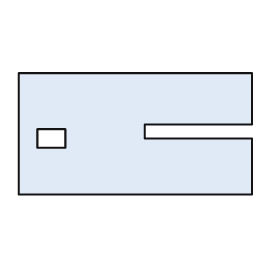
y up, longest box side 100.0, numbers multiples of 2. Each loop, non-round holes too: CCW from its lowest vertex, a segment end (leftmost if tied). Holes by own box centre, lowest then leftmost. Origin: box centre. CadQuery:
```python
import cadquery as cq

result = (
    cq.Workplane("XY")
    .moveTo(-50.0, -26.0)
    .lineTo(50.0, -26.0)
    .lineTo(50.0, -2.0)
    .lineTo(4.0, -2.0)
    .lineTo(4.0, 4.0)
    .lineTo(50.0, 4.0)
    .lineTo(50.0, 26.0)
    .lineTo(-50.0, 26.0)
    .close()
    .moveTo(-42.0, -6.0)
    .lineTo(-30.0, -6.0)
    .lineTo(-30.0, 2.0)
    .lineTo(-42.0, 2.0)
    .close()
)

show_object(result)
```